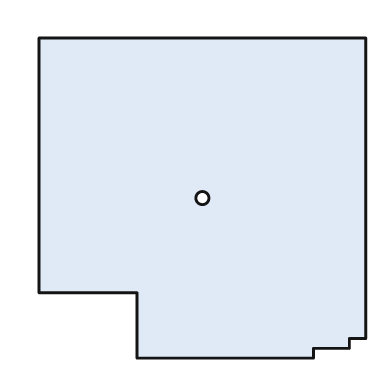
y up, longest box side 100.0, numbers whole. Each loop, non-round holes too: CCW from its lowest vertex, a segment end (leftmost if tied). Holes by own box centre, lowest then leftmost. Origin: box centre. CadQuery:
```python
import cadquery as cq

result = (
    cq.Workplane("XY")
    .moveTo(-20.0, -49.0)
    .lineTo(34.0, -49.0)
    .lineTo(34.0, -46.0)
    .lineTo(45.0, -46.0)
    .lineTo(45.0, -43.0)
    .lineTo(50.0, -43.0)
    .lineTo(50.0, 49.0)
    .lineTo(-50.0, 49.0)
    .lineTo(-50.0, -29.0)
    .lineTo(-20.0, -29.0)
    .close()
    .moveTo(0.0, 0.0)
    .circle(2.0)
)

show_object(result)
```